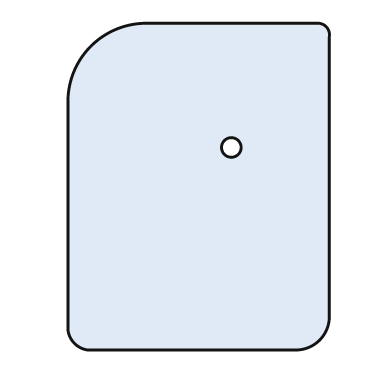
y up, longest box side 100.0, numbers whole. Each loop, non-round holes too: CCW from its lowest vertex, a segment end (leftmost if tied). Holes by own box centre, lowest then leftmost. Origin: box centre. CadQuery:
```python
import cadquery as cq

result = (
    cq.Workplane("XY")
    .moveTo(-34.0, -50.0)
    .lineTo(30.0, -50.0)
    .threePointArc((37.0, -47.0), (40.0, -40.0))
    .lineTo(40.0, 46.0)
    .threePointArc((39.0, 49.0), (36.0, 50.0))
    .lineTo(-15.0, 50.0)
    .threePointArc((-33.0, 43.0), (-40.0, 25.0))
    .lineTo(-40.0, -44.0)
    .threePointArc((-38.0, -48.0), (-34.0, -50.0))
    .close()
    .moveTo(10.0, 12.0)
    .circle(3.0)
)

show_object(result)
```